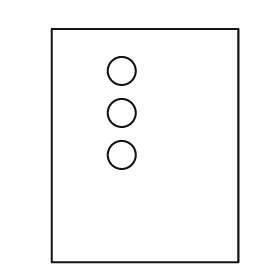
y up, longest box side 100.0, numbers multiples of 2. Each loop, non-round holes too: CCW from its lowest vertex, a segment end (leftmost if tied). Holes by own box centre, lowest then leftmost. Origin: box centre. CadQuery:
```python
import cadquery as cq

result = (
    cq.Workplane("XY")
    .moveTo(-40.0, -50.0)
    .lineTo(40.0, -50.0)
    .lineTo(40.0, 50.0)
    .lineTo(-40.0, 50.0)
    .close()
    .moveTo(-10.0, -4.0)
    .circle(6.0)
    .moveTo(-10.0, 14.0)
    .circle(6.0)
    .moveTo(-10.0, 32.0)
    .circle(6.0)
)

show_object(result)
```